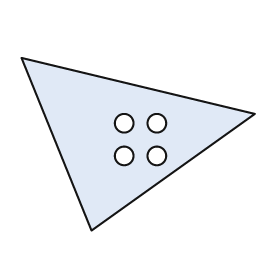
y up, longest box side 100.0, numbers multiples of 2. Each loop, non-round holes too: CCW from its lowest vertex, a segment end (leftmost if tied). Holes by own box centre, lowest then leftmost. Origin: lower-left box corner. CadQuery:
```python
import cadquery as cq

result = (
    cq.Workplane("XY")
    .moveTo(30.0, 0.0)
    .lineTo(100.0, 50.0)
    .lineTo(0.0, 74.0)
    .close()
    .moveTo(44.0, 32.0)
    .circle(4.0)
    .moveTo(58.0, 32.0)
    .circle(4.0)
    .moveTo(44.0, 46.0)
    .circle(4.0)
    .moveTo(58.0, 46.0)
    .circle(4.0)
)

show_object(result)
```